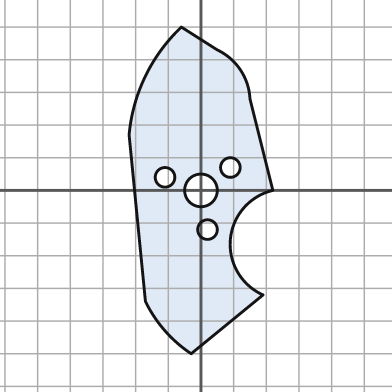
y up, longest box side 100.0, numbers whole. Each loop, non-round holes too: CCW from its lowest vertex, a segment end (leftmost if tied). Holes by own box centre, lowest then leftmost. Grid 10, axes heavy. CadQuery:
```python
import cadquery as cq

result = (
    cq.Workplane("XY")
    .moveTo(-3.0, -50.0)
    .lineTo(19.0, -32.0)
    .threePointArc((9.0, -15.0), (22.0, 0.0))
    .lineTo(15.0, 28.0)
    .threePointArc((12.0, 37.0), (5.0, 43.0))
    .lineTo(-6.0, 50.0)
    .threePointArc((-17.0, 35.0), (-22.0, 17.0))
    .lineTo(-17.0, -34.0)
    .threePointArc((-11.0, -43.0), (-3.0, -50.0))
    .close()
    .moveTo(2.0, -12.0)
    .circle(3.0)
    .moveTo(0.0, 0.0)
    .circle(5.0)
    .moveTo(-11.0, 4.0)
    .circle(3.0)
    .moveTo(9.0, 7.0)
    .circle(3.0)
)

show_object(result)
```